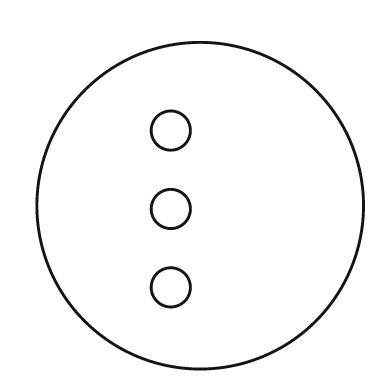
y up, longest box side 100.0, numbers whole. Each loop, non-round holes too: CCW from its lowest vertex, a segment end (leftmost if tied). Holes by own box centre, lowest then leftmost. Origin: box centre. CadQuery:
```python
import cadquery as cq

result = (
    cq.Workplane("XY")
    .moveTo(0.0, 0.0)
    .circle(50.0)
    .moveTo(-9.0, -25.0)
    .circle(6.0)
    .moveTo(-9.0, -1.0)
    .circle(6.0)
    .moveTo(-9.0, 23.0)
    .circle(6.0)
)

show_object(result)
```